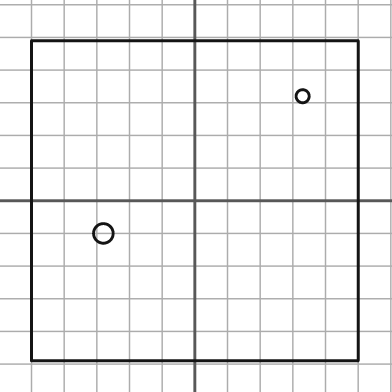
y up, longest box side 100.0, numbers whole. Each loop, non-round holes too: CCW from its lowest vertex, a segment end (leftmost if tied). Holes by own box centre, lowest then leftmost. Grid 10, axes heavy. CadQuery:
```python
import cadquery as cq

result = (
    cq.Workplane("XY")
    .moveTo(-50.0, -49.0)
    .lineTo(50.0, -49.0)
    .lineTo(50.0, 49.0)
    .lineTo(-50.0, 49.0)
    .close()
    .moveTo(-28.0, -10.0)
    .circle(3.0)
    .moveTo(33.0, 32.0)
    .circle(2.0)
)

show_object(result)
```